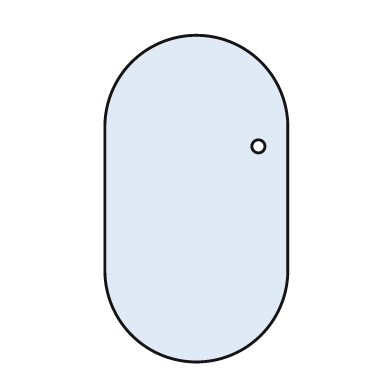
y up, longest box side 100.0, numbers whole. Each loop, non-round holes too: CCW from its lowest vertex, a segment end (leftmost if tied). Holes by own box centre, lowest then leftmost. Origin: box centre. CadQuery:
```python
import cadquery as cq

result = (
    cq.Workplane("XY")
    .moveTo(-28.0, -22.0)
    .threePointArc((0.0, -50.0), (28.0, -22.0))
    .lineTo(28.0, 22.0)
    .threePointArc((0.0, 50.0), (-28.0, 22.0))
    .close()
    .moveTo(19.0, 16.0)
    .circle(2.0)
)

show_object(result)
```